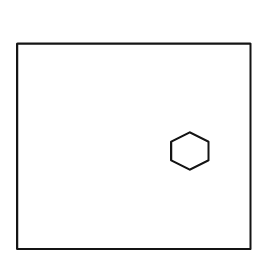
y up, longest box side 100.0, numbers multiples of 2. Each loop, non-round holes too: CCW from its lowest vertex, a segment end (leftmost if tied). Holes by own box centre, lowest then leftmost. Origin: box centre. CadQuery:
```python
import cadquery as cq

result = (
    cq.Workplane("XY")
    .moveTo(-50.0, -44.0)
    .lineTo(50.0, -44.0)
    .lineTo(50.0, 44.0)
    .lineTo(-50.0, 44.0)
    .close()
    .moveTo(24.0, -10.0)
    .lineTo(32.0, -6.0)
    .lineTo(32.0, 2.0)
    .lineTo(24.0, 6.0)
    .lineTo(16.0, 2.0)
    .lineTo(16.0, -6.0)
    .close()
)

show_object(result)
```